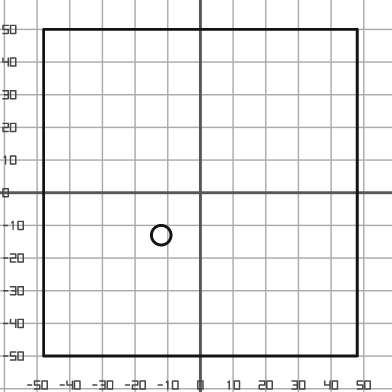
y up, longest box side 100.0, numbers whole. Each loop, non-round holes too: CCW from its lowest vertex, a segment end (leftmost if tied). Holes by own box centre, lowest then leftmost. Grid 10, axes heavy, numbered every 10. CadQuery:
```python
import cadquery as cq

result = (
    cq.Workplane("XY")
    .moveTo(-48.0, -50.0)
    .lineTo(48.0, -50.0)
    .lineTo(48.0, 50.0)
    .lineTo(-48.0, 50.0)
    .close()
    .moveTo(-12.0, -13.0)
    .circle(3.0)
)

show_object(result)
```